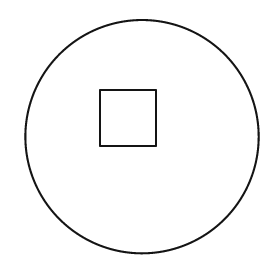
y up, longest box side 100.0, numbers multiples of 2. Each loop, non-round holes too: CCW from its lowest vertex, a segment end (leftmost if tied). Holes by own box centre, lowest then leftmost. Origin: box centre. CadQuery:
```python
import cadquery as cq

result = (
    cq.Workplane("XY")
    .moveTo(0.0, 0.0)
    .circle(50.0)
    .moveTo(-18.0, -4.0)
    .lineTo(6.0, -4.0)
    .lineTo(6.0, 20.0)
    .lineTo(-18.0, 20.0)
    .close()
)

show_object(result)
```